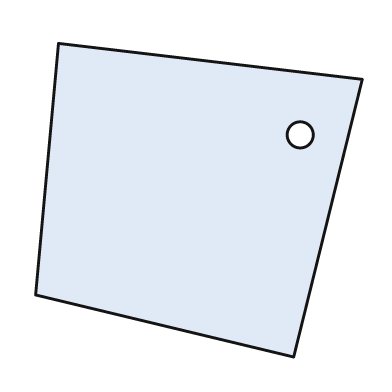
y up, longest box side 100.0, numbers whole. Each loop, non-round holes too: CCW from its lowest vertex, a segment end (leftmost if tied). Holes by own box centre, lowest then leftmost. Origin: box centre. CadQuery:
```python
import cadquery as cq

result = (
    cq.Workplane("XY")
    .moveTo(29.0, -48.0)
    .lineTo(50.0, 37.0)
    .lineTo(-43.0, 48.0)
    .lineTo(-50.0, -29.0)
    .close()
    .moveTo(31.0, 20.0)
    .circle(4.0)
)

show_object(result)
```